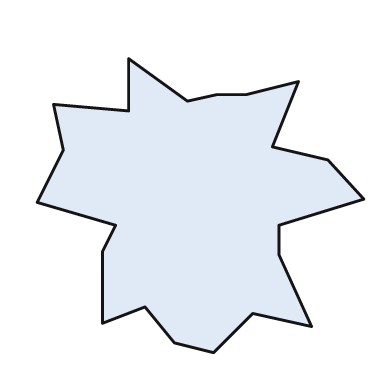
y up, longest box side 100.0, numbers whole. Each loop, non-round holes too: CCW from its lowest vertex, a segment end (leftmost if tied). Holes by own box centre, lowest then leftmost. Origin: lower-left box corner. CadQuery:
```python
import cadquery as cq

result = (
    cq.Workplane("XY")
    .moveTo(54.0, 0.0)
    .lineTo(66.0, 12.0)
    .lineTo(84.0, 8.0)
    .lineTo(74.0, 30.0)
    .lineTo(74.0, 39.0)
    .lineTo(100.0, 47.0)
    .lineTo(89.0, 59.0)
    .lineTo(72.0, 63.0)
    .lineTo(80.0, 83.0)
    .lineTo(64.0, 79.0)
    .lineTo(55.0, 79.0)
    .lineTo(46.0, 77.0)
    .lineTo(28.0, 90.0)
    .lineTo(28.0, 74.0)
    .lineTo(5.0, 76.0)
    .lineTo(8.0, 62.0)
    .lineTo(0.0, 46.0)
    .lineTo(24.0, 39.0)
    .lineTo(20.0, 31.0)
    .lineTo(20.0, 9.0)
    .lineTo(33.0, 14.0)
    .lineTo(42.0, 3.0)
    .close()
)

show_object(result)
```